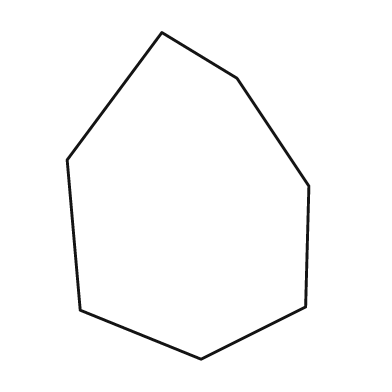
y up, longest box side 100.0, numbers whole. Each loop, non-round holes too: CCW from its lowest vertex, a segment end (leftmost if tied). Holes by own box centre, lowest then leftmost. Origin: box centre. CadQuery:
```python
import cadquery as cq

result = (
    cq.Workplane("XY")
    .moveTo(4.0, -50.0)
    .lineTo(36.0, -34.0)
    .lineTo(37.0, 3.0)
    .lineTo(15.0, 36.0)
    .lineTo(-8.0, 50.0)
    .lineTo(-37.0, 11.0)
    .lineTo(-33.0, -35.0)
    .close()
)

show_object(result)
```